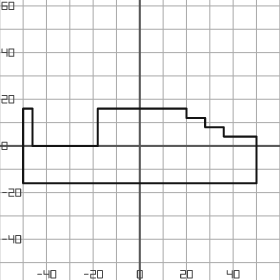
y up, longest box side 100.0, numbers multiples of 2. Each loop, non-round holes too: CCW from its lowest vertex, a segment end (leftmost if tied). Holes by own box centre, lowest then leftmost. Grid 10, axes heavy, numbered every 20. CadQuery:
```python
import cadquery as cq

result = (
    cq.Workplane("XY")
    .moveTo(-50.0, -16.0)
    .lineTo(50.0, -16.0)
    .lineTo(50.0, 4.0)
    .lineTo(36.0, 4.0)
    .lineTo(36.0, 8.0)
    .lineTo(28.0, 8.0)
    .lineTo(28.0, 12.0)
    .lineTo(20.0, 12.0)
    .lineTo(20.0, 16.0)
    .lineTo(-18.0, 16.0)
    .lineTo(-18.0, 0.0)
    .lineTo(-46.0, 0.0)
    .lineTo(-46.0, 16.0)
    .lineTo(-50.0, 16.0)
    .close()
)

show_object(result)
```